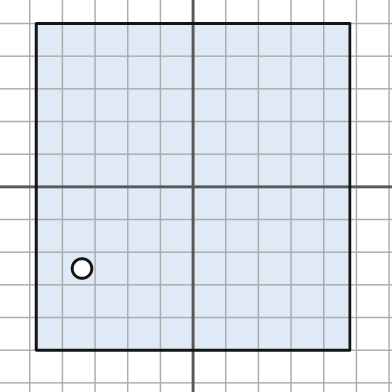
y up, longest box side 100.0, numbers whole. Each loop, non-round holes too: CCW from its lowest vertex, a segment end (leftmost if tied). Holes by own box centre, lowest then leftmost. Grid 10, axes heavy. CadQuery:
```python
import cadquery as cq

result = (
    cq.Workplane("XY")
    .moveTo(-48.0, -50.0)
    .lineTo(48.0, -50.0)
    .lineTo(48.0, 50.0)
    .lineTo(-48.0, 50.0)
    .close()
    .moveTo(-34.0, -25.0)
    .circle(3.0)
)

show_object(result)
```